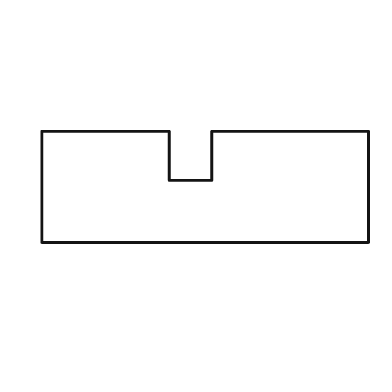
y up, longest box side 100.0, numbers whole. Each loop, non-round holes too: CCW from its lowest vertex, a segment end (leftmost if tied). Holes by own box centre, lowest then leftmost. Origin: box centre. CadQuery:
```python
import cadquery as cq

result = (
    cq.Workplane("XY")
    .moveTo(-50.0, -17.0)
    .lineTo(50.0, -17.0)
    .lineTo(50.0, 17.0)
    .lineTo(2.0, 17.0)
    .lineTo(2.0, 2.0)
    .lineTo(-11.0, 2.0)
    .lineTo(-11.0, 17.0)
    .lineTo(-50.0, 17.0)
    .close()
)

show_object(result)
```